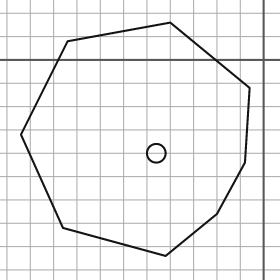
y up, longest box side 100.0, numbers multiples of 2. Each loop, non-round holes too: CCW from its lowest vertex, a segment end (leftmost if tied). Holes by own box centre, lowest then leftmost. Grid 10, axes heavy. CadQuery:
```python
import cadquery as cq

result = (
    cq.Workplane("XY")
    .moveTo(-42.0, -84.0)
    .lineTo(-20.0, -66.0)
    .lineTo(-8.0, -44.0)
    .lineTo(-6.0, -12.0)
    .lineTo(-40.0, 16.0)
    .lineTo(-84.0, 8.0)
    .lineTo(-104.0, -32.0)
    .lineTo(-86.0, -72.0)
    .close()
    .moveTo(-46.0, -40.0)
    .circle(4.0)
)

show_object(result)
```